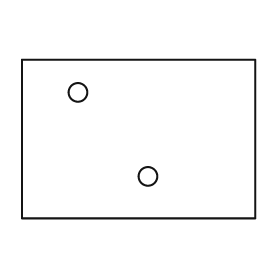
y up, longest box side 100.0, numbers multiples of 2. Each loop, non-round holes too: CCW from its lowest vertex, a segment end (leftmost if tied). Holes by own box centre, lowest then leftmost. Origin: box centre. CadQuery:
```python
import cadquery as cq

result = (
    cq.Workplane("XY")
    .moveTo(-50.0, -34.0)
    .lineTo(50.0, -34.0)
    .lineTo(50.0, 34.0)
    .lineTo(-50.0, 34.0)
    .close()
    .moveTo(4.0, -16.0)
    .circle(4.0)
    .moveTo(-26.0, 20.0)
    .circle(4.0)
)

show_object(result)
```